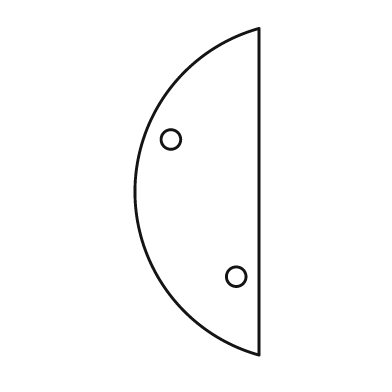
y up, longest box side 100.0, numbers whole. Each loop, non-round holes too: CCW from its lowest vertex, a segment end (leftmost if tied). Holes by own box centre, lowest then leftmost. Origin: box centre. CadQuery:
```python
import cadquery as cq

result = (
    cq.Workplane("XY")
    .moveTo(19.0, -50.0)
    .lineTo(19.0, 50.0)
    .threePointArc((-19.0, 0.0), (19.0, -50.0))
    .close()
    .moveTo(12.0, -26.0)
    .circle(3.0)
    .moveTo(-8.0, 16.0)
    .circle(3.0)
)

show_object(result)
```